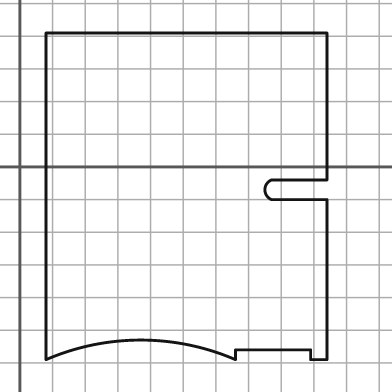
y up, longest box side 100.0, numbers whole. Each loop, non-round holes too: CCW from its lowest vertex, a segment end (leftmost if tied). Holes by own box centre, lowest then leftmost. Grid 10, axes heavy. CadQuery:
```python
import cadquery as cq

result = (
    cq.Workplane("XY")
    .moveTo(8.0, -59.0)
    .threePointArc((37.0, -53.0), (66.0, -59.0))
    .lineTo(66.0, -56.0)
    .lineTo(89.0, -56.0)
    .lineTo(89.0, -59.0)
    .lineTo(94.0, -59.0)
    .lineTo(94.0, -10.0)
    .lineTo(77.0, -10.0)
    .threePointArc((75.0, -7.0), (77.0, -4.0))
    .lineTo(94.0, -4.0)
    .lineTo(94.0, 41.0)
    .lineTo(8.0, 41.0)
    .close()
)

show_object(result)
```